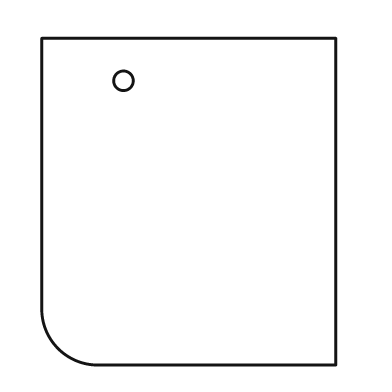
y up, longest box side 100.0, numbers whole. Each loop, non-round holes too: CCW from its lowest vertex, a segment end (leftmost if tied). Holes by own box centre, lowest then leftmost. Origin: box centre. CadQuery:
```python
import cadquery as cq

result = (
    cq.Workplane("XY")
    .moveTo(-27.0, -50.0)
    .lineTo(45.0, -50.0)
    .lineTo(45.0, 50.0)
    .lineTo(-45.0, 50.0)
    .lineTo(-45.0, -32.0)
    .threePointArc((-40.0, -45.0), (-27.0, -50.0))
    .close()
    .moveTo(-20.0, 37.0)
    .circle(3.0)
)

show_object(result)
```